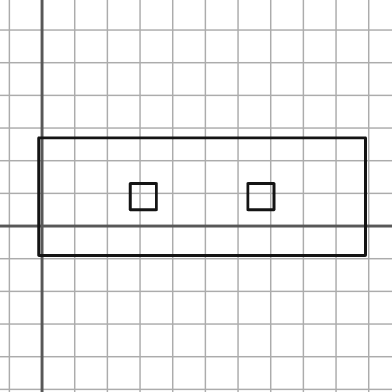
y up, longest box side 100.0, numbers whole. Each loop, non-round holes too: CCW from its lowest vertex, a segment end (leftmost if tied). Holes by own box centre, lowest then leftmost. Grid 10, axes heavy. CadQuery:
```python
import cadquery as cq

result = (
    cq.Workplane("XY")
    .moveTo(-1.0, -9.0)
    .lineTo(99.0, -9.0)
    .lineTo(99.0, 27.0)
    .lineTo(-1.0, 27.0)
    .close()
    .moveTo(27.0, 5.0)
    .lineTo(35.0, 5.0)
    .lineTo(35.0, 13.0)
    .lineTo(27.0, 13.0)
    .close()
    .moveTo(63.0, 5.0)
    .lineTo(71.0, 5.0)
    .lineTo(71.0, 13.0)
    .lineTo(63.0, 13.0)
    .close()
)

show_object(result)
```